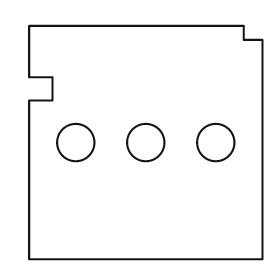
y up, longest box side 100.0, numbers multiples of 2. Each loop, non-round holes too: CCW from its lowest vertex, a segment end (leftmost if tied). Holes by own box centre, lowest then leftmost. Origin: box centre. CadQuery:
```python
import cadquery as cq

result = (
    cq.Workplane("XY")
    .moveTo(-50.0, -50.0)
    .lineTo(50.0, -50.0)
    .lineTo(50.0, 44.0)
    .lineTo(42.0, 44.0)
    .lineTo(42.0, 50.0)
    .lineTo(-50.0, 50.0)
    .lineTo(-50.0, 28.0)
    .lineTo(-40.0, 28.0)
    .lineTo(-40.0, 18.0)
    .lineTo(-50.0, 18.0)
    .close()
    .moveTo(-30.0, 0.0)
    .circle(8.0)
    .moveTo(0.0, 0.0)
    .circle(8.0)
    .moveTo(30.0, 0.0)
    .circle(8.0)
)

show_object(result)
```